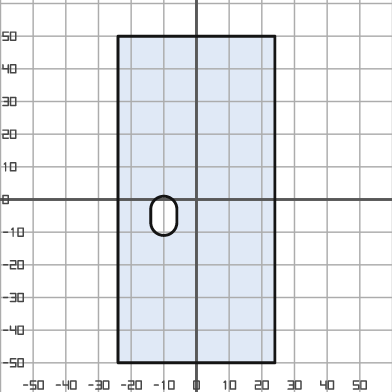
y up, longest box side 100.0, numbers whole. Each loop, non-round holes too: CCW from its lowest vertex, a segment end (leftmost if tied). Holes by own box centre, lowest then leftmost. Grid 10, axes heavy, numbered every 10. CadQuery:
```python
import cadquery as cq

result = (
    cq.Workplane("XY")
    .moveTo(-24.0, -50.0)
    .lineTo(24.0, -50.0)
    .lineTo(24.0, 50.0)
    .lineTo(-24.0, 50.0)
    .close()
    .moveTo(-14.0, -7.0)
    .threePointArc((-10.0, -11.0), (-6.0, -7.0))
    .lineTo(-6.0, -3.0)
    .threePointArc((-10.0, 1.0), (-14.0, -3.0))
    .close()
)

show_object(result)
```